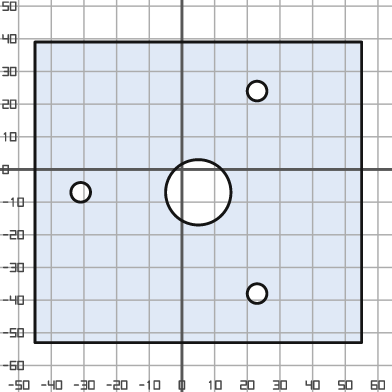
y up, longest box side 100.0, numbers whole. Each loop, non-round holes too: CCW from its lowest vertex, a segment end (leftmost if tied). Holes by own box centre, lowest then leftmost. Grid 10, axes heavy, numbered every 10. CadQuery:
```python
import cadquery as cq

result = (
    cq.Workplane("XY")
    .moveTo(-45.0, -53.0)
    .lineTo(55.0, -53.0)
    .lineTo(55.0, 39.0)
    .lineTo(-45.0, 39.0)
    .close()
    .moveTo(23.0, -38.0)
    .circle(3.0)
    .moveTo(-31.0, -7.0)
    .circle(3.0)
    .moveTo(5.0, -7.0)
    .circle(10.0)
    .moveTo(23.0, 24.0)
    .circle(3.0)
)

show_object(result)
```